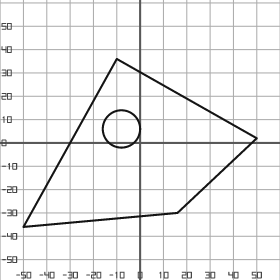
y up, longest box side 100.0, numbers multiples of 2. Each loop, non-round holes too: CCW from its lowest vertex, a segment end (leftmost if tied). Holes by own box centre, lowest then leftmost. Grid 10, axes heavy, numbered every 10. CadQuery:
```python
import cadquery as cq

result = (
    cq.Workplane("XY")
    .moveTo(-50.0, -36.0)
    .lineTo(16.0, -30.0)
    .lineTo(50.0, 2.0)
    .lineTo(-10.0, 36.0)
    .close()
    .moveTo(-8.0, 6.0)
    .circle(8.0)
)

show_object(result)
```